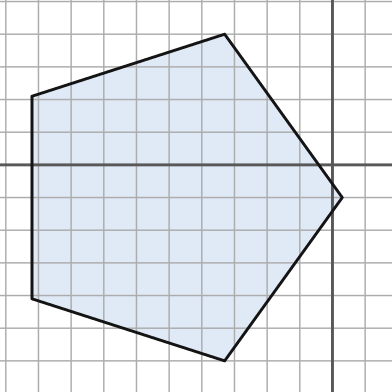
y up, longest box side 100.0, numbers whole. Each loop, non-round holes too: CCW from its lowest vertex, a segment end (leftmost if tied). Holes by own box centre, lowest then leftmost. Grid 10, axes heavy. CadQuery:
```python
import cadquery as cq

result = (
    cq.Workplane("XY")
    .moveTo(-33.0, -60.0)
    .lineTo(3.0, -10.0)
    .lineTo(-33.0, 40.0)
    .lineTo(-92.0, 21.0)
    .lineTo(-92.0, -41.0)
    .close()
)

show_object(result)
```